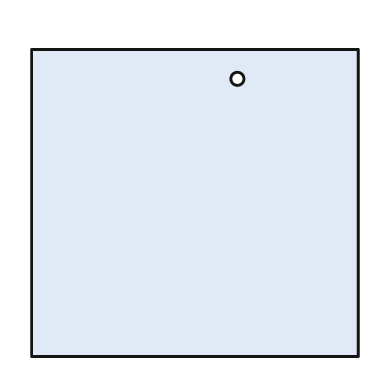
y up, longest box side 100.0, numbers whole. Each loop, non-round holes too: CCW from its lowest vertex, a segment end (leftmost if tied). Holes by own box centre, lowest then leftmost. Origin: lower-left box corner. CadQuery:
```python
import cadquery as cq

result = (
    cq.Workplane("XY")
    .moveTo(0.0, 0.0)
    .lineTo(100.0, 0.0)
    .lineTo(100.0, 94.0)
    .lineTo(0.0, 94.0)
    .close()
    .moveTo(63.0, 85.0)
    .circle(2.0)
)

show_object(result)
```